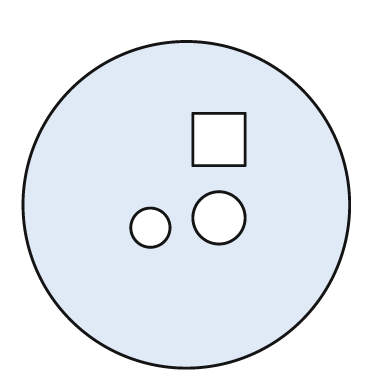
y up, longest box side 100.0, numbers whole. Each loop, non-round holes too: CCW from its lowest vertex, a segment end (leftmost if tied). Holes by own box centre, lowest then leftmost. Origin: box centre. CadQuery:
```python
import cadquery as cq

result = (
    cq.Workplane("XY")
    .moveTo(0.0, 0.0)
    .circle(50.0)
    .moveTo(-11.0, -7.0)
    .circle(6.0)
    .moveTo(10.0, -4.0)
    .circle(8.0)
    .moveTo(2.0, 12.0)
    .lineTo(18.0, 12.0)
    .lineTo(18.0, 28.0)
    .lineTo(2.0, 28.0)
    .close()
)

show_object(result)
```